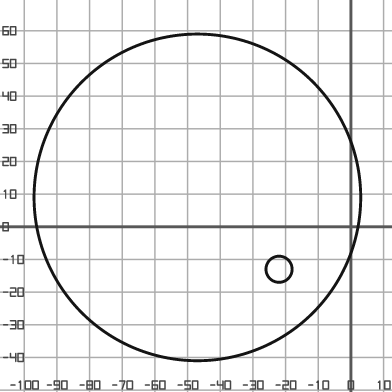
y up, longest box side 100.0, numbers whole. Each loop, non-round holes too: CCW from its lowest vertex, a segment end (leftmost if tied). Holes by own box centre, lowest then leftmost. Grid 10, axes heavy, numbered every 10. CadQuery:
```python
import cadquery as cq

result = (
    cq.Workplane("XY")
    .moveTo(-47.0, 9.0)
    .circle(50.0)
    .moveTo(-22.0, -13.0)
    .circle(4.0)
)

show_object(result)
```